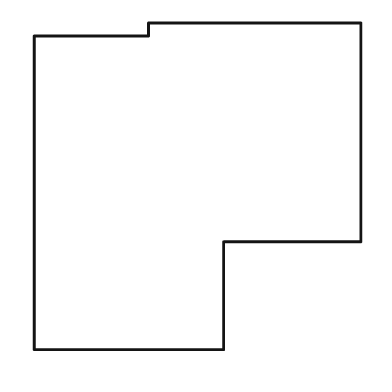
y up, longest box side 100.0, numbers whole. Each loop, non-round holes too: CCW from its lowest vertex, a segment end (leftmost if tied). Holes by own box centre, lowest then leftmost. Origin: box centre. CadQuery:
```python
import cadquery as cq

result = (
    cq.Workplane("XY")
    .moveTo(-50.0, -50.0)
    .lineTo(8.0, -50.0)
    .lineTo(8.0, -17.0)
    .lineTo(50.0, -17.0)
    .lineTo(50.0, 50.0)
    .lineTo(-15.0, 50.0)
    .lineTo(-15.0, 46.0)
    .lineTo(-50.0, 46.0)
    .close()
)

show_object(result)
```